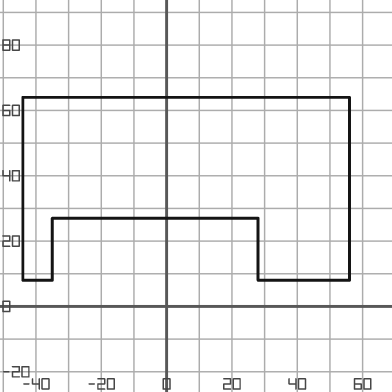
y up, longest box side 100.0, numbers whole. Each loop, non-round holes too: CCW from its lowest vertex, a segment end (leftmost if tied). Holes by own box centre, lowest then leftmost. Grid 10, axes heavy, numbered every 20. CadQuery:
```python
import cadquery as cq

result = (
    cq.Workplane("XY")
    .moveTo(-44.0, 8.0)
    .lineTo(-35.0, 8.0)
    .lineTo(-35.0, 27.0)
    .lineTo(28.0, 27.0)
    .lineTo(28.0, 8.0)
    .lineTo(56.0, 8.0)
    .lineTo(56.0, 64.0)
    .lineTo(-44.0, 64.0)
    .close()
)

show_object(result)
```